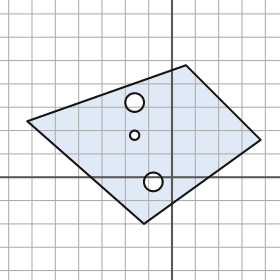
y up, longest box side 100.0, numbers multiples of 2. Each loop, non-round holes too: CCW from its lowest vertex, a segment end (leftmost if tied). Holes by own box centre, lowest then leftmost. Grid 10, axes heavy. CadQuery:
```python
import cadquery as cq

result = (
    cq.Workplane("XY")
    .moveTo(-12.0, -20.0)
    .lineTo(38.0, 16.0)
    .lineTo(6.0, 48.0)
    .lineTo(-62.0, 24.0)
    .close()
    .moveTo(-8.0, -2.0)
    .circle(4.0)
    .moveTo(-16.0, 18.0)
    .circle(2.0)
    .moveTo(-16.0, 32.0)
    .circle(4.0)
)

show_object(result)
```